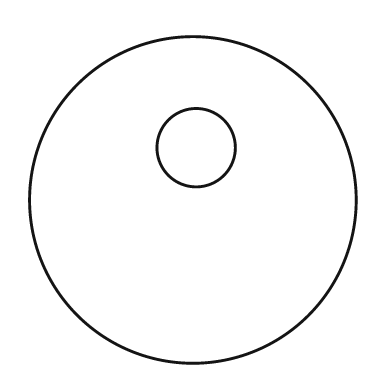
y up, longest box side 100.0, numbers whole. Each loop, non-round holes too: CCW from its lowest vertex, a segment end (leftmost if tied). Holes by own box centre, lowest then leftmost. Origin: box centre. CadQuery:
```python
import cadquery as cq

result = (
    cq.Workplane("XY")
    .moveTo(0.0, 0.0)
    .circle(50.0)
    .moveTo(1.0, 16.0)
    .circle(12.0)
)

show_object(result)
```